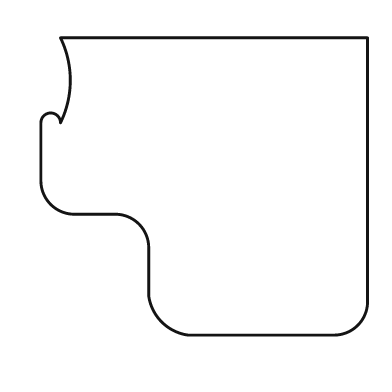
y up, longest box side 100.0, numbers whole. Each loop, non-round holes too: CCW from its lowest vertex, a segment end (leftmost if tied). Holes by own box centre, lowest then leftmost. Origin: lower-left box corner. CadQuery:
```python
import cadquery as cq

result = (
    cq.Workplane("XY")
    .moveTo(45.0, 0.0)
    .lineTo(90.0, 0.0)
    .threePointArc((97.0, 3.0), (100.0, 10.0))
    .lineTo(100.0, 91.0)
    .lineTo(6.0, 91.0)
    .threePointArc((9.0, 78.0), (6.0, 65.0))
    .threePointArc((3.0, 68.0), (0.0, 65.0))
    .lineTo(0.0, 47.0)
    .threePointArc((3.0, 40.0), (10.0, 37.0))
    .lineTo(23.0, 37.0)
    .threePointArc((30.0, 34.0), (33.0, 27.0))
    .lineTo(33.0, 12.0)
    .threePointArc((37.0, 4.0), (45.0, 0.0))
    .close()
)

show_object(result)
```